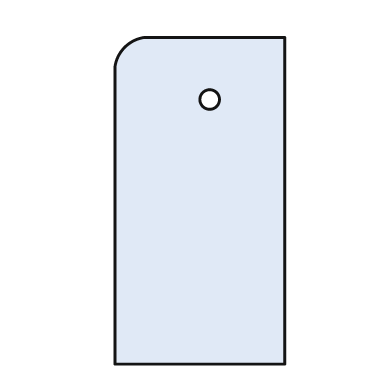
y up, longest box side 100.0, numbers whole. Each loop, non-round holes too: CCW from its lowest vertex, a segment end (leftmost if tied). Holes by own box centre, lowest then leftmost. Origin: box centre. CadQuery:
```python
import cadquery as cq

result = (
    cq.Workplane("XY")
    .moveTo(-26.0, -50.0)
    .lineTo(26.0, -50.0)
    .lineTo(26.0, 50.0)
    .lineTo(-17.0, 50.0)
    .threePointArc((-23.0, 47.0), (-26.0, 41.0))
    .close()
    .moveTo(3.0, 31.0)
    .circle(3.0)
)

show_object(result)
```